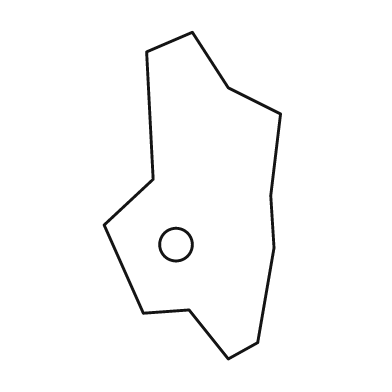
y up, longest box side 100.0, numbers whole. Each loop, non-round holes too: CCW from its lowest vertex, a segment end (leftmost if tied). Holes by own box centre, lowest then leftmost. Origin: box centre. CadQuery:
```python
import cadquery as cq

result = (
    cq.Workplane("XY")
    .moveTo(11.0, -50.0)
    .lineTo(20.0, -45.0)
    .lineTo(25.0, -16.0)
    .lineTo(24.0, 0.0)
    .lineTo(27.0, 25.0)
    .lineTo(11.0, 33.0)
    .lineTo(0.0, 50.0)
    .lineTo(-14.0, 44.0)
    .lineTo(-12.0, 5.0)
    .lineTo(-27.0, -9.0)
    .lineTo(-15.0, -36.0)
    .lineTo(-1.0, -35.0)
    .close()
    .moveTo(-5.0, -15.0)
    .circle(5.0)
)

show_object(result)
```